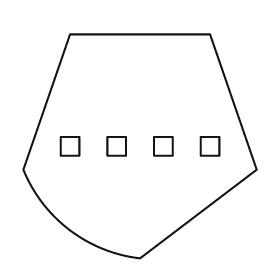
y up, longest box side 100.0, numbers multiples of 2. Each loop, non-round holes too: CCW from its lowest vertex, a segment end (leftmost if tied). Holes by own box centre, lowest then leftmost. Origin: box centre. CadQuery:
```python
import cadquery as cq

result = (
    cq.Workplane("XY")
    .moveTo(0.0, -48.0)
    .lineTo(50.0, -10.0)
    .lineTo(30.0, 48.0)
    .lineTo(-30.0, 48.0)
    .lineTo(-50.0, -10.0)
    .threePointArc((-30.0, -36.0), (0.0, -48.0))
    .close()
    .moveTo(-34.0, -4.0)
    .lineTo(-26.0, -4.0)
    .lineTo(-26.0, 4.0)
    .lineTo(-34.0, 4.0)
    .close()
    .moveTo(-14.0, -4.0)
    .lineTo(-6.0, -4.0)
    .lineTo(-6.0, 4.0)
    .lineTo(-14.0, 4.0)
    .close()
    .moveTo(6.0, -4.0)
    .lineTo(14.0, -4.0)
    .lineTo(14.0, 4.0)
    .lineTo(6.0, 4.0)
    .close()
    .moveTo(26.0, -4.0)
    .lineTo(34.0, -4.0)
    .lineTo(34.0, 4.0)
    .lineTo(26.0, 4.0)
    .close()
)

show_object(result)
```